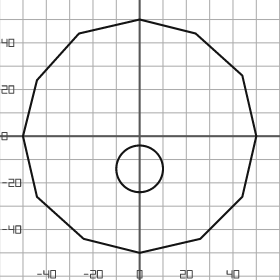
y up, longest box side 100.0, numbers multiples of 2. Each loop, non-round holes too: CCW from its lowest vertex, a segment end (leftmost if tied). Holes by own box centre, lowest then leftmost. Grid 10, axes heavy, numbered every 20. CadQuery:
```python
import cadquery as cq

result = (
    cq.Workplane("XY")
    .moveTo(0.0, -50.0)
    .lineTo(26.0, -44.0)
    .lineTo(44.0, -26.0)
    .lineTo(50.0, 0.0)
    .lineTo(44.0, 26.0)
    .lineTo(24.0, 44.0)
    .lineTo(0.0, 50.0)
    .lineTo(-26.0, 44.0)
    .lineTo(-44.0, 24.0)
    .lineTo(-50.0, 0.0)
    .lineTo(-44.0, -26.0)
    .lineTo(-24.0, -44.0)
    .close()
    .moveTo(0.0, -14.0)
    .circle(10.0)
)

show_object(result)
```